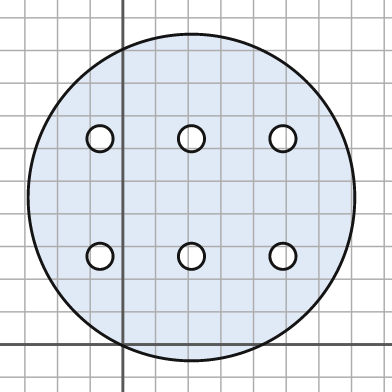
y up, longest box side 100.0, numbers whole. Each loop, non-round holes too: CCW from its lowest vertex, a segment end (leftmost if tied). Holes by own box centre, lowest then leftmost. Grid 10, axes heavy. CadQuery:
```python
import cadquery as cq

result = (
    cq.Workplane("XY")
    .moveTo(21.0, 45.0)
    .circle(50.0)
    .moveTo(-7.0, 27.0)
    .circle(4.0)
    .moveTo(21.0, 27.0)
    .circle(4.0)
    .moveTo(49.0, 27.0)
    .circle(4.0)
    .moveTo(-7.0, 63.0)
    .circle(4.0)
    .moveTo(21.0, 63.0)
    .circle(4.0)
    .moveTo(49.0, 63.0)
    .circle(4.0)
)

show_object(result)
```